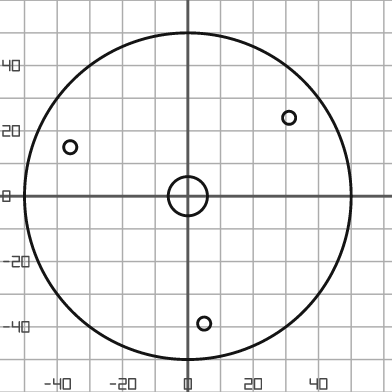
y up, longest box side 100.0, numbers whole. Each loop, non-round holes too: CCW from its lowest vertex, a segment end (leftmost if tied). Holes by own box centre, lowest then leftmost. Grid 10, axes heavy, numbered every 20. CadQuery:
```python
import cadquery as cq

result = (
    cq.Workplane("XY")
    .moveTo(0.0, 0.0)
    .circle(50.0)
    .moveTo(5.0, -39.0)
    .circle(2.0)
    .moveTo(0.0, 0.0)
    .circle(6.0)
    .moveTo(-36.0, 15.0)
    .circle(2.0)
    .moveTo(31.0, 24.0)
    .circle(2.0)
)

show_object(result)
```